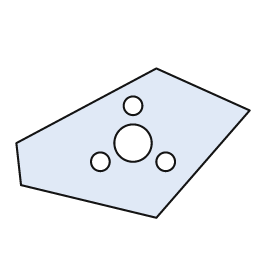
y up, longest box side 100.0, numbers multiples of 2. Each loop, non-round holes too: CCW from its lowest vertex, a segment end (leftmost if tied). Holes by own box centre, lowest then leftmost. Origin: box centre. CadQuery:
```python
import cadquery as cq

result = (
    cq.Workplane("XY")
    .moveTo(10.0, -32.0)
    .lineTo(50.0, 14.0)
    .lineTo(10.0, 32.0)
    .lineTo(-50.0, 0.0)
    .lineTo(-48.0, -18.0)
    .close()
    .moveTo(-14.0, -8.0)
    .circle(4.0)
    .moveTo(14.0, -8.0)
    .circle(4.0)
    .moveTo(0.0, 0.0)
    .circle(8.0)
    .moveTo(0.0, 16.0)
    .circle(4.0)
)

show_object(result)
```